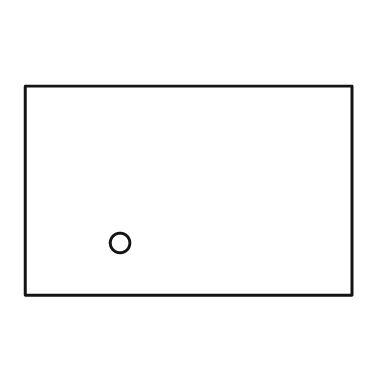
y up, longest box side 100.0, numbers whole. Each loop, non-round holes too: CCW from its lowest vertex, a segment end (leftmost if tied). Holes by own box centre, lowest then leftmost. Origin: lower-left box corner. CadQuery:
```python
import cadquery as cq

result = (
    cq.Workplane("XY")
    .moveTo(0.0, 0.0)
    .lineTo(100.0, 0.0)
    .lineTo(100.0, 64.0)
    .lineTo(0.0, 64.0)
    .close()
    .moveTo(29.0, 16.0)
    .circle(3.0)
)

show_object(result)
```